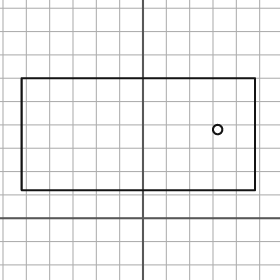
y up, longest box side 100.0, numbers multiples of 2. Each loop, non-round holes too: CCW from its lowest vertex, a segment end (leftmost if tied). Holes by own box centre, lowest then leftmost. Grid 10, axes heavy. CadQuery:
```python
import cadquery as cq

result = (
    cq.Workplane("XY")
    .moveTo(-52.0, 12.0)
    .lineTo(48.0, 12.0)
    .lineTo(48.0, 60.0)
    .lineTo(-52.0, 60.0)
    .close()
    .moveTo(32.0, 38.0)
    .circle(2.0)
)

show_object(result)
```